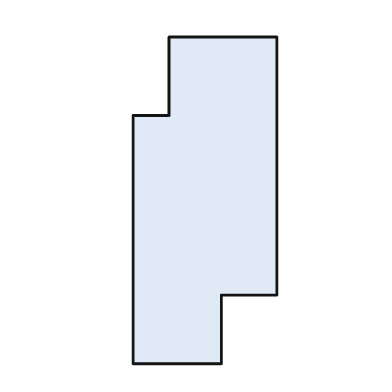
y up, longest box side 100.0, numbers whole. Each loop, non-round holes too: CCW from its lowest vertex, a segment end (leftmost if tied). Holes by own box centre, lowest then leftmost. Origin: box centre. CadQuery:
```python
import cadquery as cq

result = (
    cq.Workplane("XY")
    .moveTo(-22.0, -50.0)
    .lineTo(5.0, -50.0)
    .lineTo(5.0, -29.0)
    .lineTo(22.0, -29.0)
    .lineTo(22.0, 50.0)
    .lineTo(-11.0, 50.0)
    .lineTo(-11.0, 26.0)
    .lineTo(-22.0, 26.0)
    .close()
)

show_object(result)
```